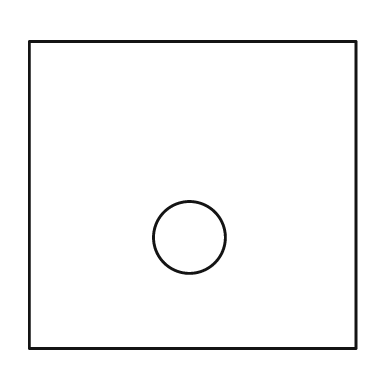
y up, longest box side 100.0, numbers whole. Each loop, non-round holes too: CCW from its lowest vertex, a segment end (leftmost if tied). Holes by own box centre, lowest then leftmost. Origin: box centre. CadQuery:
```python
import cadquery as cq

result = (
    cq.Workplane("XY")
    .moveTo(-50.0, -47.0)
    .lineTo(50.0, -47.0)
    .lineTo(50.0, 47.0)
    .lineTo(-50.0, 47.0)
    .close()
    .moveTo(-1.0, -13.0)
    .circle(11.0)
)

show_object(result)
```